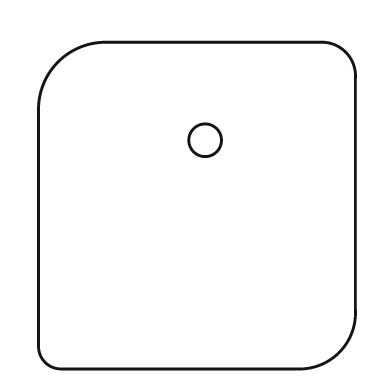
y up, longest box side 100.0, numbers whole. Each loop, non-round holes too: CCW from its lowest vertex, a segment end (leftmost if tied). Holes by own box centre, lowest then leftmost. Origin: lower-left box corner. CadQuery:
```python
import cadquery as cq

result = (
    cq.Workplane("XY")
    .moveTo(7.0, 0.0)
    .lineTo(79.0, 0.0)
    .threePointArc((92.0, 5.0), (97.0, 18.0))
    .lineTo(97.0, 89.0)
    .threePointArc((94.0, 97.0), (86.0, 100.0))
    .lineTo(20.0, 100.0)
    .threePointArc((6.0, 94.0), (0.0, 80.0))
    .lineTo(0.0, 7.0)
    .threePointArc((2.0, 2.0), (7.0, 0.0))
    .close()
    .moveTo(51.0, 70.0)
    .circle(5.0)
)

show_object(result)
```